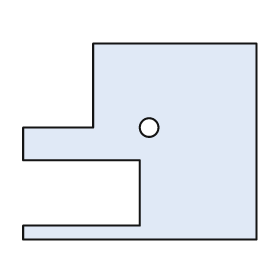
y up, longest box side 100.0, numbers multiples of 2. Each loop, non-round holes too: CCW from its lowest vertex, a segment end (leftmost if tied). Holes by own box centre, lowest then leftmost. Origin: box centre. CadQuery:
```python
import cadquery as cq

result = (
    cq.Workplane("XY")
    .moveTo(-50.0, -42.0)
    .lineTo(50.0, -42.0)
    .lineTo(50.0, 42.0)
    .lineTo(-20.0, 42.0)
    .lineTo(-20.0, 6.0)
    .lineTo(-50.0, 6.0)
    .lineTo(-50.0, -8.0)
    .lineTo(0.0, -8.0)
    .lineTo(0.0, -36.0)
    .lineTo(-50.0, -36.0)
    .close()
    .moveTo(4.0, 6.0)
    .circle(4.0)
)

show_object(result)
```